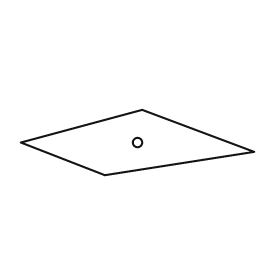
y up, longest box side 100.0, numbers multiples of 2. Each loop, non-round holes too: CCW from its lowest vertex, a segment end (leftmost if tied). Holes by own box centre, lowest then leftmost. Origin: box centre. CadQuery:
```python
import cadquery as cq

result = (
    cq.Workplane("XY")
    .moveTo(-14.0, -14.0)
    .lineTo(50.0, -4.0)
    .lineTo(2.0, 14.0)
    .lineTo(-50.0, 0.0)
    .close()
    .moveTo(0.0, 0.0)
    .circle(2.0)
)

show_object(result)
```